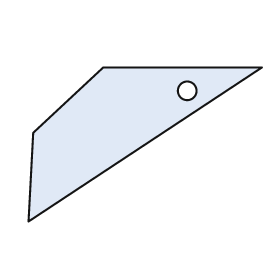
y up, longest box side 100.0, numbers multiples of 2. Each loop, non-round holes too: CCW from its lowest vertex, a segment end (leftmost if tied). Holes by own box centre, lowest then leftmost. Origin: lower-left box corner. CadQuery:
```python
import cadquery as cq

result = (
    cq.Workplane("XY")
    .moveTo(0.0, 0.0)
    .lineTo(100.0, 66.0)
    .lineTo(32.0, 66.0)
    .lineTo(2.0, 38.0)
    .close()
    .moveTo(68.0, 56.0)
    .circle(4.0)
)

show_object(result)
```